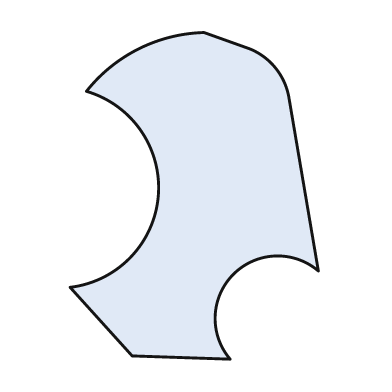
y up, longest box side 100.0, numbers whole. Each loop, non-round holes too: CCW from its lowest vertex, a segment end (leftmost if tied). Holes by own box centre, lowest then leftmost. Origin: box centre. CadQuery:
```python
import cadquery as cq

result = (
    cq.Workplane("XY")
    .moveTo(11.0, -50.0)
    .threePointArc((12.0, -24.0), (38.0, -23.0))
    .lineTo(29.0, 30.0)
    .threePointArc((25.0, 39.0), (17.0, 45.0))
    .lineTo(3.0, 50.0)
    .threePointArc((-17.0, 45.0), (-33.0, 32.0))
    .threePointArc((-11.0, 0.0), (-38.0, -28.0))
    .lineTo(-19.0, -49.0)
    .close()
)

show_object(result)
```